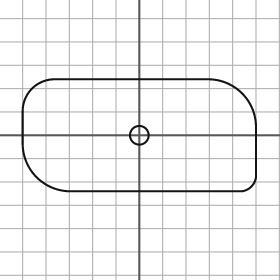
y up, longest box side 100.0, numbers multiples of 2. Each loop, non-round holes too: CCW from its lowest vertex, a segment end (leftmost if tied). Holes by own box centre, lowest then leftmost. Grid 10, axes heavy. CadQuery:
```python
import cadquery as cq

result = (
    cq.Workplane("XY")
    .moveTo(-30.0, -24.0)
    .lineTo(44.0, -24.0)
    .threePointArc((48.0, -22.0), (50.0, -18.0))
    .lineTo(50.0, 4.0)
    .threePointArc((44.0, 18.0), (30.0, 24.0))
    .lineTo(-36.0, 24.0)
    .threePointArc((-46.0, 20.0), (-50.0, 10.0))
    .lineTo(-50.0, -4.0)
    .threePointArc((-44.0, -18.0), (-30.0, -24.0))
    .close()
    .moveTo(0.0, 0.0)
    .circle(4.0)
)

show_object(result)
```